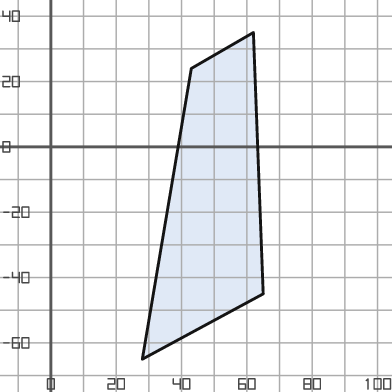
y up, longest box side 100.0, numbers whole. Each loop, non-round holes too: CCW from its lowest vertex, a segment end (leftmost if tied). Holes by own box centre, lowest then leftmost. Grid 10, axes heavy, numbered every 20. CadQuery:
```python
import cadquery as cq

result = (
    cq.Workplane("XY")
    .moveTo(28.0, -65.0)
    .lineTo(65.0, -45.0)
    .lineTo(62.0, 35.0)
    .lineTo(43.0, 24.0)
    .close()
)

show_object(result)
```